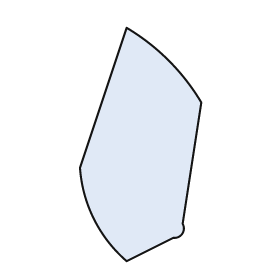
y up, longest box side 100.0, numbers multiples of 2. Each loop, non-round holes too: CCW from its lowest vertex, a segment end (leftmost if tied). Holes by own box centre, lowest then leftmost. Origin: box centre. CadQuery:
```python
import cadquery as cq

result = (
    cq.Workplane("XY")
    .moveTo(-6.0, -50.0)
    .lineTo(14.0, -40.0)
    .threePointArc((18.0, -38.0), (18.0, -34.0))
    .lineTo(26.0, 18.0)
    .threePointArc((12.0, 36.0), (-6.0, 50.0))
    .lineTo(-26.0, -10.0)
    .threePointArc((-20.0, -32.0), (-6.0, -50.0))
    .close()
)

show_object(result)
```